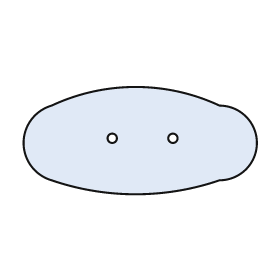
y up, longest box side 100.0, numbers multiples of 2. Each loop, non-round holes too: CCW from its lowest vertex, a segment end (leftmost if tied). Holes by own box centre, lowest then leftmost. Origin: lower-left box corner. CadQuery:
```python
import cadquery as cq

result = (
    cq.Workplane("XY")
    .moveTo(12.0, 6.0)
    .threePointArc((48.0, 0.0), (84.0, 6.0))
    .threePointArc((100.0, 22.0), (84.0, 38.0))
    .threePointArc((48.0, 46.0), (12.0, 38.0))
    .threePointArc((0.0, 22.0), (12.0, 6.0))
    .close()
    .moveTo(38.0, 24.0)
    .circle(2.0)
    .moveTo(64.0, 24.0)
    .circle(2.0)
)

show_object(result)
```